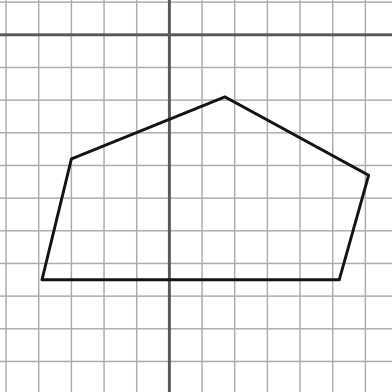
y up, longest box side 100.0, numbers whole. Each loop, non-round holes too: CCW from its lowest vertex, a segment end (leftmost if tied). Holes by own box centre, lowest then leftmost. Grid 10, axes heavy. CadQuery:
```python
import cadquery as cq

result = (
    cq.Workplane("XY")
    .moveTo(-39.0, -75.0)
    .lineTo(52.0, -75.0)
    .lineTo(61.0, -43.0)
    .lineTo(17.0, -19.0)
    .lineTo(-30.0, -38.0)
    .close()
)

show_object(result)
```